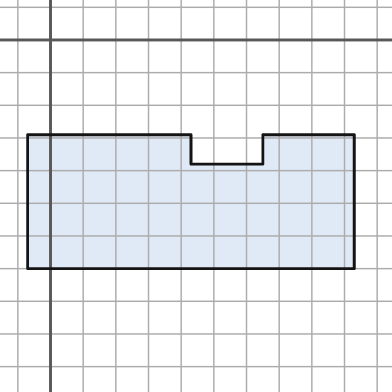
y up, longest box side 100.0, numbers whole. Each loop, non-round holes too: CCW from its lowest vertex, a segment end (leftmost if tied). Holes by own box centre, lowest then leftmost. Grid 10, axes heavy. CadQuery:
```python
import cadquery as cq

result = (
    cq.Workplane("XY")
    .moveTo(-7.0, -70.0)
    .lineTo(93.0, -70.0)
    .lineTo(93.0, -29.0)
    .lineTo(65.0, -29.0)
    .lineTo(65.0, -38.0)
    .lineTo(43.0, -38.0)
    .lineTo(43.0, -29.0)
    .lineTo(-7.0, -29.0)
    .close()
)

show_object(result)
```